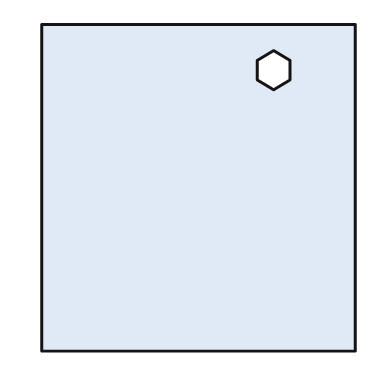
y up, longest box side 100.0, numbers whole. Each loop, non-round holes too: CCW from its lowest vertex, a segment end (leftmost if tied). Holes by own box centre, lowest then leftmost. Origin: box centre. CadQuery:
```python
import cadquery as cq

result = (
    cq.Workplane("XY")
    .moveTo(-48.0, -50.0)
    .lineTo(48.0, -50.0)
    .lineTo(48.0, 50.0)
    .lineTo(-48.0, 50.0)
    .close()
    .moveTo(23.0, 30.0)
    .lineTo(28.0, 33.0)
    .lineTo(28.0, 39.0)
    .lineTo(23.0, 42.0)
    .lineTo(18.0, 39.0)
    .lineTo(18.0, 33.0)
    .close()
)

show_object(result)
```